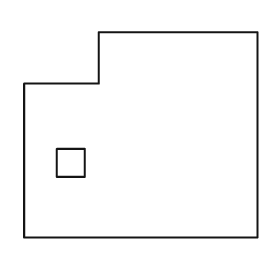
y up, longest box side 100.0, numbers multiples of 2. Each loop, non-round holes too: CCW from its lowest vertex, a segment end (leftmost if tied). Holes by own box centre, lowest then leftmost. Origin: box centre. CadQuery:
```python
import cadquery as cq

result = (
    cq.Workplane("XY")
    .moveTo(-50.0, -44.0)
    .lineTo(50.0, -44.0)
    .lineTo(50.0, 44.0)
    .lineTo(-18.0, 44.0)
    .lineTo(-18.0, 22.0)
    .lineTo(-50.0, 22.0)
    .close()
    .moveTo(-36.0, -18.0)
    .lineTo(-24.0, -18.0)
    .lineTo(-24.0, -6.0)
    .lineTo(-36.0, -6.0)
    .close()
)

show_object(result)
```